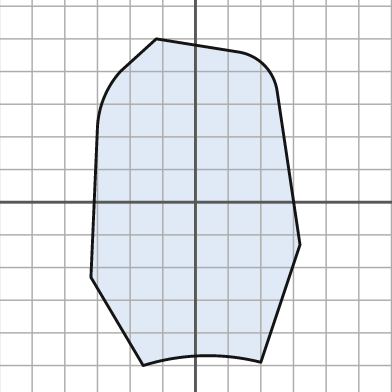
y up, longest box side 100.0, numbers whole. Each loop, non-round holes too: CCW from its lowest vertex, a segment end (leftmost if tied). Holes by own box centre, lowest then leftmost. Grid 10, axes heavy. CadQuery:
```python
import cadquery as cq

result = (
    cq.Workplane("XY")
    .moveTo(-16.0, -50.0)
    .threePointArc((2.0, -47.0), (20.0, -49.0))
    .lineTo(32.0, -13.0)
    .lineTo(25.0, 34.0)
    .threePointArc((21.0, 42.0), (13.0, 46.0))
    .lineTo(-12.0, 50.0)
    .lineTo(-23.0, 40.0)
    .threePointArc((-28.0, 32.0), (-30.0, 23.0))
    .lineTo(-32.0, -23.0)
    .close()
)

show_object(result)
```